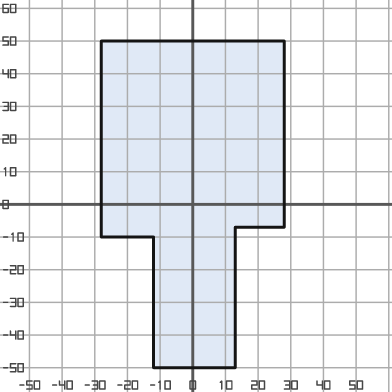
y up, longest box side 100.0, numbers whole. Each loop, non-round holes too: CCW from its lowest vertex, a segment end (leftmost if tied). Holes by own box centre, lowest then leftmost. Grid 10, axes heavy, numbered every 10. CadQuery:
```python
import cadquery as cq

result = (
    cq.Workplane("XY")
    .moveTo(-12.0, -50.0)
    .lineTo(13.0, -50.0)
    .lineTo(13.0, -7.0)
    .lineTo(28.0, -7.0)
    .lineTo(28.0, 50.0)
    .lineTo(-28.0, 50.0)
    .lineTo(-28.0, -10.0)
    .lineTo(-12.0, -10.0)
    .close()
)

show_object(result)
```